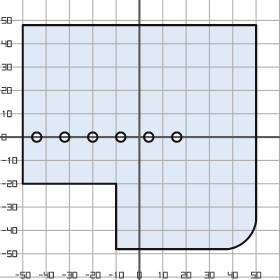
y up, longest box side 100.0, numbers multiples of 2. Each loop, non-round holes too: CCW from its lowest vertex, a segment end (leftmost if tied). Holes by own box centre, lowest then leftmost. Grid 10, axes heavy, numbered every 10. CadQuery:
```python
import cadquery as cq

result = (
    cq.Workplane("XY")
    .moveTo(-10.0, -48.0)
    .lineTo(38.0, -48.0)
    .threePointArc((46.0, -44.0), (50.0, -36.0))
    .lineTo(50.0, 48.0)
    .lineTo(-50.0, 48.0)
    .lineTo(-50.0, -20.0)
    .lineTo(-10.0, -20.0)
    .close()
    .moveTo(-44.0, 0.0)
    .circle(2.0)
    .moveTo(-32.0, 0.0)
    .circle(2.0)
    .moveTo(-20.0, 0.0)
    .circle(2.0)
    .moveTo(-8.0, 0.0)
    .circle(2.0)
    .moveTo(4.0, 0.0)
    .circle(2.0)
    .moveTo(16.0, 0.0)
    .circle(2.0)
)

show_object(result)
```